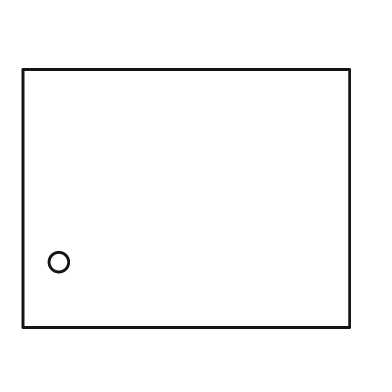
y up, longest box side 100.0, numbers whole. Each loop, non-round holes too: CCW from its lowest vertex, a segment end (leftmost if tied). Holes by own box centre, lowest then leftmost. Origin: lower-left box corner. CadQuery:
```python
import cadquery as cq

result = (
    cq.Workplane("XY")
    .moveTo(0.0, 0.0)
    .lineTo(100.0, 0.0)
    .lineTo(100.0, 79.0)
    .lineTo(0.0, 79.0)
    .close()
    .moveTo(11.0, 20.0)
    .circle(3.0)
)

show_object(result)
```